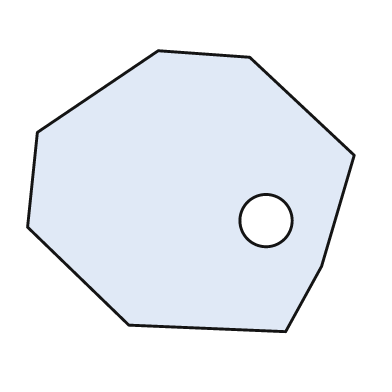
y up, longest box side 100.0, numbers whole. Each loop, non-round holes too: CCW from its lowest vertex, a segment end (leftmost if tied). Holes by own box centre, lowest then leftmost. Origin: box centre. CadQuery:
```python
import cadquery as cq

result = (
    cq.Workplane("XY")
    .moveTo(29.0, -43.0)
    .lineTo(40.0, -23.0)
    .lineTo(50.0, 11.0)
    .lineTo(18.0, 41.0)
    .lineTo(-10.0, 43.0)
    .lineTo(-47.0, 18.0)
    .lineTo(-50.0, -11.0)
    .lineTo(-19.0, -41.0)
    .close()
    .moveTo(23.0, -9.0)
    .circle(8.0)
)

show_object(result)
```